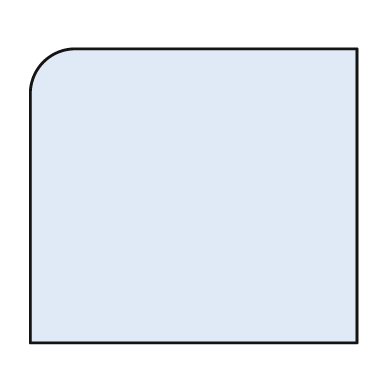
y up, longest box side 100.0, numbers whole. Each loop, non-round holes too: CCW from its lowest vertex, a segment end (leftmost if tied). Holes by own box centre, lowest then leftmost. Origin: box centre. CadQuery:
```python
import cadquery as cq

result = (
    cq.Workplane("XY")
    .moveTo(-50.0, -45.0)
    .lineTo(50.0, -45.0)
    .lineTo(50.0, 45.0)
    .lineTo(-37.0, 45.0)
    .threePointArc((-46.0, 41.0), (-50.0, 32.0))
    .close()
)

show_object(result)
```